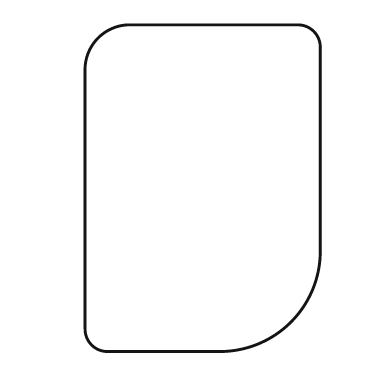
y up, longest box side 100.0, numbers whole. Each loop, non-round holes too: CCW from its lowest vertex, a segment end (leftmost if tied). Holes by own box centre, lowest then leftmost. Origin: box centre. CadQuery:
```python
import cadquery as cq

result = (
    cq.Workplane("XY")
    .moveTo(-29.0, -50.0)
    .lineTo(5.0, -50.0)
    .threePointArc((27.0, -41.0), (36.0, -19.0))
    .lineTo(36.0, 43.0)
    .threePointArc((34.0, 48.0), (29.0, 50.0))
    .lineTo(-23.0, 50.0)
    .threePointArc((-32.0, 46.0), (-36.0, 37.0))
    .lineTo(-36.0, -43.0)
    .threePointArc((-34.0, -48.0), (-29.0, -50.0))
    .close()
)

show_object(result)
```